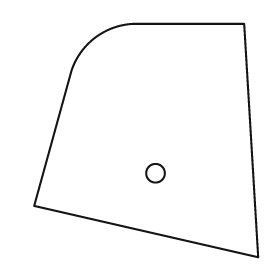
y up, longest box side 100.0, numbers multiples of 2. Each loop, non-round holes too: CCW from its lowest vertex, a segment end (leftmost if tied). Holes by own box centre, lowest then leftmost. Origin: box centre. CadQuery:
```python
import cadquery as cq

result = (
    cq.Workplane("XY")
    .moveTo(48.0, -50.0)
    .lineTo(42.0, 50.0)
    .lineTo(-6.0, 50.0)
    .threePointArc((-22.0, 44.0), (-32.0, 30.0))
    .lineTo(-48.0, -28.0)
    .close()
    .moveTo(4.0, -14.0)
    .circle(4.0)
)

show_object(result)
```